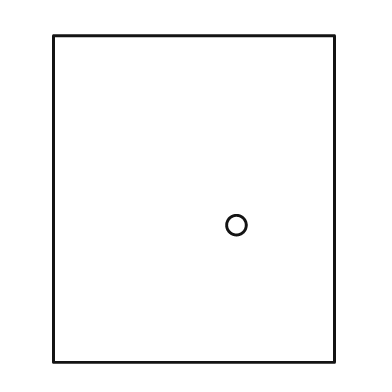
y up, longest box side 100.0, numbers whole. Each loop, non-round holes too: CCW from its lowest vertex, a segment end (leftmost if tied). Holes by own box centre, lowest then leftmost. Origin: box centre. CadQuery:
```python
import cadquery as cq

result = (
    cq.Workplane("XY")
    .moveTo(-43.0, -50.0)
    .lineTo(43.0, -50.0)
    .lineTo(43.0, 50.0)
    .lineTo(-43.0, 50.0)
    .close()
    .moveTo(13.0, -8.0)
    .circle(3.0)
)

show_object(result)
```